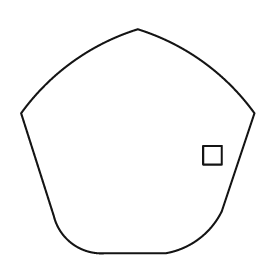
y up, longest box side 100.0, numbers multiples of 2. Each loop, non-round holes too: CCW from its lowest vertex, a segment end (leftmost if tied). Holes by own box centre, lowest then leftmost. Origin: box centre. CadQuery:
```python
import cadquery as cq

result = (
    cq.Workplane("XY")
    .moveTo(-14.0, -48.0)
    .lineTo(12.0, -48.0)
    .threePointArc((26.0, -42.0), (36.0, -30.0))
    .lineTo(50.0, 12.0)
    .threePointArc((28.0, 34.0), (0.0, 48.0))
    .threePointArc((-28.0, 34.0), (-50.0, 12.0))
    .lineTo(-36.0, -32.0)
    .threePointArc((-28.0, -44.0), (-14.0, -48.0))
    .close()
    .moveTo(28.0, -10.0)
    .lineTo(36.0, -10.0)
    .lineTo(36.0, -2.0)
    .lineTo(28.0, -2.0)
    .close()
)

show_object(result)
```